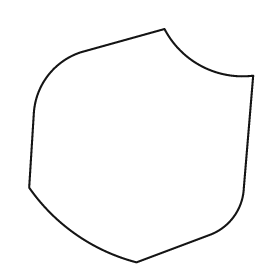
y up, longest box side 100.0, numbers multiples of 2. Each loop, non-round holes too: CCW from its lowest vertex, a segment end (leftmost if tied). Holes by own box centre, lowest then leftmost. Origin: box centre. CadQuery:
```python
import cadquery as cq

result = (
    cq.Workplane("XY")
    .moveTo(-2.0, -50.0)
    .lineTo(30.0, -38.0)
    .threePointArc((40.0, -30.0), (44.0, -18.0))
    .lineTo(48.0, 30.0)
    .threePointArc((26.0, 34.0), (10.0, 50.0))
    .lineTo(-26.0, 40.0)
    .threePointArc((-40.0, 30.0), (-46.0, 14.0))
    .lineTo(-48.0, -18.0)
    .threePointArc((-28.0, -38.0), (-2.0, -50.0))
    .close()
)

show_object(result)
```